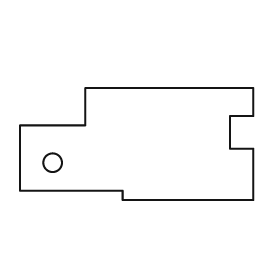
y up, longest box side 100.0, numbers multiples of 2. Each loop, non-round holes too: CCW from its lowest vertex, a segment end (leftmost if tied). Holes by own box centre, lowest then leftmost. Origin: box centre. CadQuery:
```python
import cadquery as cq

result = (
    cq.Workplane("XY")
    .moveTo(-6.0, -24.0)
    .lineTo(50.0, -24.0)
    .lineTo(50.0, -2.0)
    .lineTo(40.0, -2.0)
    .lineTo(40.0, 12.0)
    .lineTo(50.0, 12.0)
    .lineTo(50.0, 24.0)
    .lineTo(-22.0, 24.0)
    .lineTo(-22.0, 8.0)
    .lineTo(-50.0, 8.0)
    .lineTo(-50.0, -20.0)
    .lineTo(-6.0, -20.0)
    .close()
    .moveTo(-36.0, -8.0)
    .circle(4.0)
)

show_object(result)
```